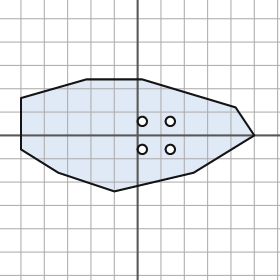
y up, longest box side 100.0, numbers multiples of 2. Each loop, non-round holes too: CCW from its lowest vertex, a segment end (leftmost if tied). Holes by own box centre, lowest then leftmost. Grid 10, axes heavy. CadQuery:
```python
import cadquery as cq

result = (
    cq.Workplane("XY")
    .moveTo(-10.0, -24.0)
    .lineTo(24.0, -16.0)
    .lineTo(50.0, 0.0)
    .lineTo(42.0, 12.0)
    .lineTo(2.0, 24.0)
    .lineTo(-22.0, 24.0)
    .lineTo(-50.0, 16.0)
    .lineTo(-50.0, -6.0)
    .lineTo(-34.0, -16.0)
    .close()
    .moveTo(2.0, -6.0)
    .circle(2.0)
    .moveTo(14.0, -6.0)
    .circle(2.0)
    .moveTo(2.0, 6.0)
    .circle(2.0)
    .moveTo(14.0, 6.0)
    .circle(2.0)
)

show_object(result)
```